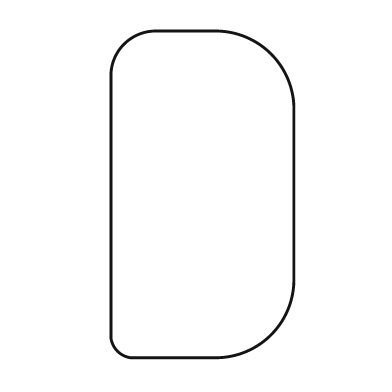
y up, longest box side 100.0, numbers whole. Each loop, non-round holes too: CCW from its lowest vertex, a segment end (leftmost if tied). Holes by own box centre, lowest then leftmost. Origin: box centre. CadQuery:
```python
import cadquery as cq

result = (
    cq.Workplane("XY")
    .moveTo(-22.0, -50.0)
    .lineTo(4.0, -50.0)
    .threePointArc((21.0, -43.0), (28.0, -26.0))
    .lineTo(28.0, 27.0)
    .threePointArc((21.0, 43.0), (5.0, 50.0))
    .lineTo(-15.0, 50.0)
    .threePointArc((-24.0, 46.0), (-28.0, 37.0))
    .lineTo(-28.0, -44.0)
    .threePointArc((-26.0, -48.0), (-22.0, -50.0))
    .close()
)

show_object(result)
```